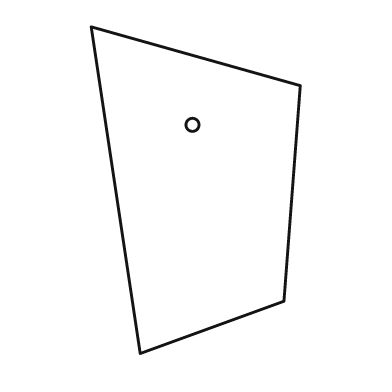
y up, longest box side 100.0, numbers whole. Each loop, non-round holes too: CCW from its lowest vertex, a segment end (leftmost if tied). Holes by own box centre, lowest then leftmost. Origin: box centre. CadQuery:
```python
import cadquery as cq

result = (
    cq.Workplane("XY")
    .moveTo(-17.0, -50.0)
    .lineTo(27.0, -34.0)
    .lineTo(32.0, 32.0)
    .lineTo(-32.0, 50.0)
    .close()
    .moveTo(-1.0, 20.0)
    .circle(2.0)
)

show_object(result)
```